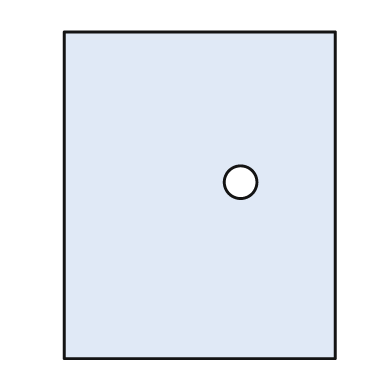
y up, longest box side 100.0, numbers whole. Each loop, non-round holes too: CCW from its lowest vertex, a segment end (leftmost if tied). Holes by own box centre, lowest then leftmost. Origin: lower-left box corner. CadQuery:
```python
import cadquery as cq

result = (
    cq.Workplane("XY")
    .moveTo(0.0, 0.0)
    .lineTo(83.0, 0.0)
    .lineTo(83.0, 100.0)
    .lineTo(0.0, 100.0)
    .close()
    .moveTo(54.0, 54.0)
    .circle(5.0)
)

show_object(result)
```